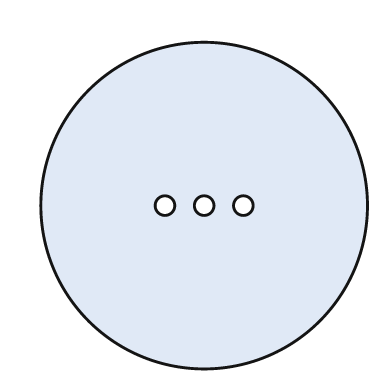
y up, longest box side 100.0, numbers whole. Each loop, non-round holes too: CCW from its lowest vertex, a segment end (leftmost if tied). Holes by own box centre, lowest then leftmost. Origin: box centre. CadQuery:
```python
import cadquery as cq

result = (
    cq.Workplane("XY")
    .moveTo(0.0, 0.0)
    .circle(50.0)
    .moveTo(-12.0, 0.0)
    .circle(3.0)
    .moveTo(0.0, 0.0)
    .circle(3.0)
    .moveTo(12.0, 0.0)
    .circle(3.0)
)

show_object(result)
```